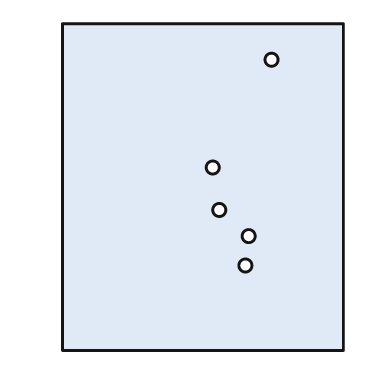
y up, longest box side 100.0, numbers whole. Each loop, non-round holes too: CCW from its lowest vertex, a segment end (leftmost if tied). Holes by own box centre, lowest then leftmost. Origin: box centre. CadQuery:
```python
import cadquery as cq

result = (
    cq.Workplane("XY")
    .moveTo(-43.0, -50.0)
    .lineTo(43.0, -50.0)
    .lineTo(43.0, 50.0)
    .lineTo(-43.0, 50.0)
    .close()
    .moveTo(13.0, -24.0)
    .circle(2.0)
    .moveTo(14.0, -15.0)
    .circle(2.0)
    .moveTo(5.0, -7.0)
    .circle(2.0)
    .moveTo(3.0, 6.0)
    .circle(2.0)
    .moveTo(21.0, 39.0)
    .circle(2.0)
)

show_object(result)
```